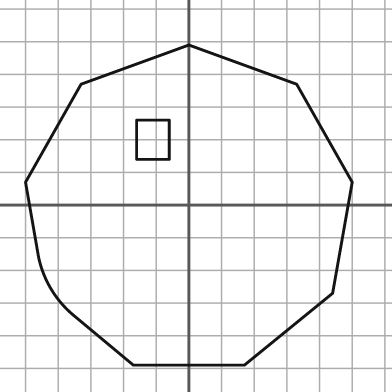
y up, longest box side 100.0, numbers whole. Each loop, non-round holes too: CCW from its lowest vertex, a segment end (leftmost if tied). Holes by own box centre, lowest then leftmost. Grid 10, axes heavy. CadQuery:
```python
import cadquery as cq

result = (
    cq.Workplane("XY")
    .moveTo(-17.0, -49.0)
    .lineTo(17.0, -49.0)
    .lineTo(44.0, -27.0)
    .lineTo(50.0, 7.0)
    .lineTo(33.0, 37.0)
    .lineTo(0.0, 49.0)
    .lineTo(-33.0, 37.0)
    .lineTo(-50.0, 7.0)
    .lineTo(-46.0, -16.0)
    .threePointArc((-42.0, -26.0), (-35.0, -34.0))
    .close()
    .moveTo(-16.0, 14.0)
    .lineTo(-6.0, 14.0)
    .lineTo(-6.0, 26.0)
    .lineTo(-16.0, 26.0)
    .close()
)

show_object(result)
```